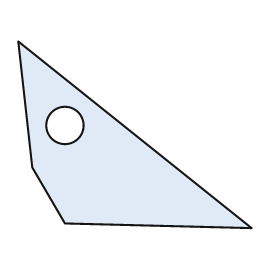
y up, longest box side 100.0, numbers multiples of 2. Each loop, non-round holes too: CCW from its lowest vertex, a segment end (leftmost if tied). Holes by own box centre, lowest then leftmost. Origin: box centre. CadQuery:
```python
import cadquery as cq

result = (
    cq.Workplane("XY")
    .moveTo(50.0, -40.0)
    .lineTo(-50.0, 40.0)
    .lineTo(-44.0, -14.0)
    .lineTo(-30.0, -38.0)
    .close()
    .moveTo(-30.0, 4.0)
    .circle(8.0)
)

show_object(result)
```